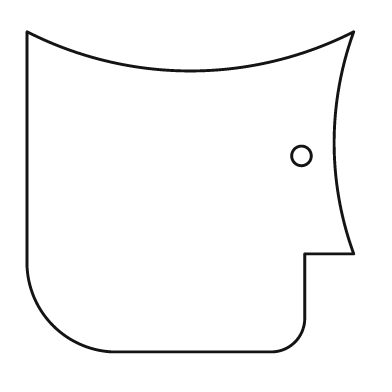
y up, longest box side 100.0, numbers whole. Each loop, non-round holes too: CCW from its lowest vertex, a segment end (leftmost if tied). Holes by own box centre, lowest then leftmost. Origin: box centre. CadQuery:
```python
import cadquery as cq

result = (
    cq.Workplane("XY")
    .moveTo(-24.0, -49.0)
    .lineTo(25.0, -49.0)
    .threePointArc((32.0, -46.0), (35.0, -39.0))
    .lineTo(35.0, -19.0)
    .lineTo(50.0, -19.0)
    .threePointArc((44.0, 15.0), (50.0, 49.0))
    .threePointArc((0.0, 37.0), (-50.0, 49.0))
    .lineTo(-50.0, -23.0)
    .threePointArc((-42.0, -41.0), (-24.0, -49.0))
    .close()
    .moveTo(34.0, 11.0)
    .circle(3.0)
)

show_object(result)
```